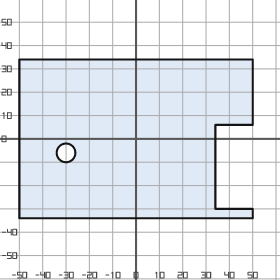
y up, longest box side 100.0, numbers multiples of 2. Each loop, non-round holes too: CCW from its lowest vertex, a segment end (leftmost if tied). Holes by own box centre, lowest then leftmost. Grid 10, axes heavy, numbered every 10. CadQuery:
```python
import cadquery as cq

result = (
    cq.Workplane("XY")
    .moveTo(-50.0, -34.0)
    .lineTo(50.0, -34.0)
    .lineTo(50.0, -30.0)
    .lineTo(34.0, -30.0)
    .lineTo(34.0, 6.0)
    .lineTo(50.0, 6.0)
    .lineTo(50.0, 34.0)
    .lineTo(-50.0, 34.0)
    .close()
    .moveTo(-30.0, -6.0)
    .circle(4.0)
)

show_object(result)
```